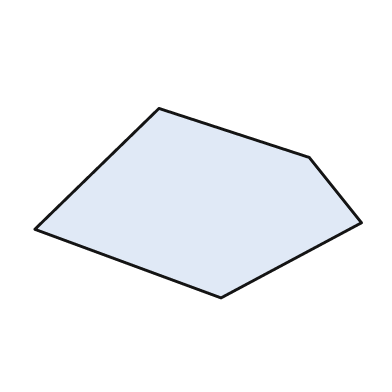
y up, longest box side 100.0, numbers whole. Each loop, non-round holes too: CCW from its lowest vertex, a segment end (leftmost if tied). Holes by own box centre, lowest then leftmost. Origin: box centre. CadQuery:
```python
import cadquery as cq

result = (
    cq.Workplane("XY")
    .moveTo(7.0, -29.0)
    .lineTo(50.0, -6.0)
    .lineTo(34.0, 14.0)
    .lineTo(-12.0, 29.0)
    .lineTo(-50.0, -8.0)
    .close()
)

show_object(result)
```